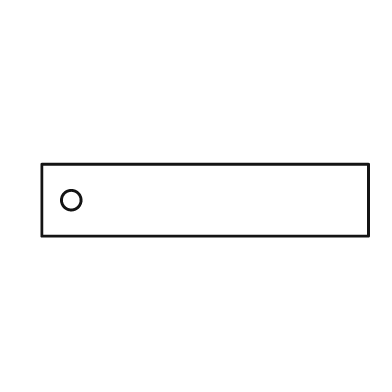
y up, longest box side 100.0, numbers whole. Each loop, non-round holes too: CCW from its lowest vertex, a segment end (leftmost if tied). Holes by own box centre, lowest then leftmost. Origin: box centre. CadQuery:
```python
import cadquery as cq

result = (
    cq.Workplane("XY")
    .moveTo(-50.0, -11.0)
    .lineTo(50.0, -11.0)
    .lineTo(50.0, 11.0)
    .lineTo(-50.0, 11.0)
    .close()
    .moveTo(-41.0, 0.0)
    .circle(3.0)
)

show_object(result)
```